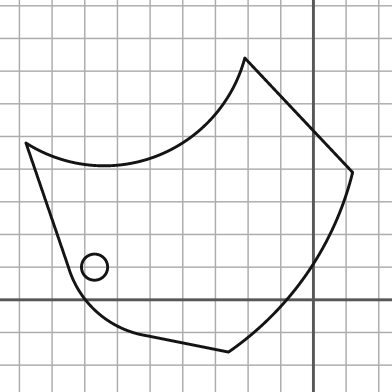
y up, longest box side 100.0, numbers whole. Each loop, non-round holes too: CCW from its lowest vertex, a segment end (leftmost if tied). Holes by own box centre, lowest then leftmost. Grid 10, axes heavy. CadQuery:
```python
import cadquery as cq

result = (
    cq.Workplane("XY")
    .moveTo(-26.0, -16.0)
    .threePointArc((-2.0, 8.0), (12.0, 39.0))
    .lineTo(-21.0, 74.0)
    .threePointArc((-48.0, 44.0), (-88.0, 48.0))
    .lineTo(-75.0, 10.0)
    .threePointArc((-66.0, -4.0), (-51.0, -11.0))
    .close()
    .moveTo(-67.0, 10.0)
    .circle(4.0)
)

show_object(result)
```